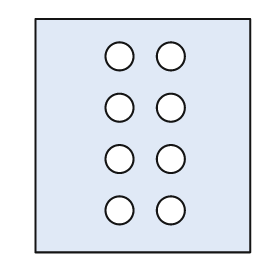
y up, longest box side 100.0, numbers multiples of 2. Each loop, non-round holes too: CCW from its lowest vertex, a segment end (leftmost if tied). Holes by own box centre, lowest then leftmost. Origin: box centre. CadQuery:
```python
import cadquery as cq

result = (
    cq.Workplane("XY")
    .moveTo(-46.0, -50.0)
    .lineTo(46.0, -50.0)
    .lineTo(46.0, 50.0)
    .lineTo(-46.0, 50.0)
    .close()
    .moveTo(-10.0, -32.0)
    .circle(6.0)
    .moveTo(12.0, -32.0)
    .circle(6.0)
    .moveTo(-10.0, -10.0)
    .circle(6.0)
    .moveTo(12.0, -10.0)
    .circle(6.0)
    .moveTo(-10.0, 12.0)
    .circle(6.0)
    .moveTo(12.0, 12.0)
    .circle(6.0)
    .moveTo(-10.0, 34.0)
    .circle(6.0)
    .moveTo(12.0, 34.0)
    .circle(6.0)
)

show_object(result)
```